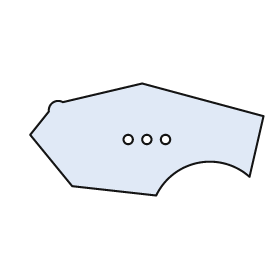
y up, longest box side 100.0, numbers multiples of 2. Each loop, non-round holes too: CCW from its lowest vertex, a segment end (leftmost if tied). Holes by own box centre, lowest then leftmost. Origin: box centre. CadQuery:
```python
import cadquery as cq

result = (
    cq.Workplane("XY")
    .moveTo(4.0, -24.0)
    .threePointArc((22.0, -10.0), (44.0, -16.0))
    .lineTo(50.0, 10.0)
    .lineTo(-2.0, 24.0)
    .lineTo(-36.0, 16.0)
    .threePointArc((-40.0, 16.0), (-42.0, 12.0))
    .lineTo(-50.0, 2.0)
    .lineTo(-32.0, -20.0)
    .close()
    .moveTo(-8.0, 0.0)
    .circle(2.0)
    .moveTo(0.0, 0.0)
    .circle(2.0)
    .moveTo(8.0, 0.0)
    .circle(2.0)
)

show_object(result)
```